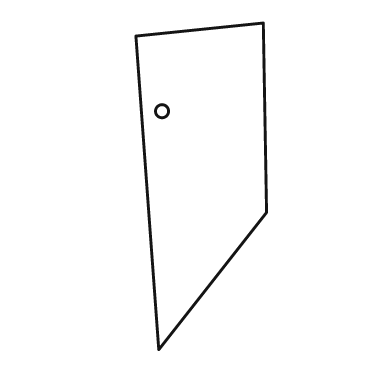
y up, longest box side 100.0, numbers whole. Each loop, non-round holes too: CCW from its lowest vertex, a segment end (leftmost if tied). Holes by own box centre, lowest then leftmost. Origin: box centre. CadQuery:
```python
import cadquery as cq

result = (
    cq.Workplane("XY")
    .moveTo(-13.0, -50.0)
    .lineTo(20.0, -8.0)
    .lineTo(19.0, 50.0)
    .lineTo(-20.0, 46.0)
    .close()
    .moveTo(-12.0, 23.0)
    .circle(2.0)
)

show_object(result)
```